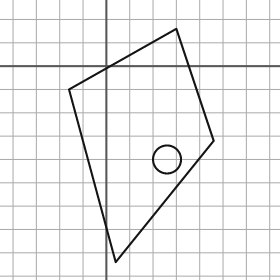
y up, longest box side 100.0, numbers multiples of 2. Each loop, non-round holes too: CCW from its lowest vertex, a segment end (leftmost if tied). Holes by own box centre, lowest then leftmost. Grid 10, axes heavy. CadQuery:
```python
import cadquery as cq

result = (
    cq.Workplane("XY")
    .moveTo(4.0, -84.0)
    .lineTo(46.0, -32.0)
    .lineTo(30.0, 16.0)
    .lineTo(-16.0, -10.0)
    .close()
    .moveTo(26.0, -40.0)
    .circle(6.0)
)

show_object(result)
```